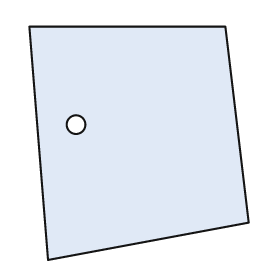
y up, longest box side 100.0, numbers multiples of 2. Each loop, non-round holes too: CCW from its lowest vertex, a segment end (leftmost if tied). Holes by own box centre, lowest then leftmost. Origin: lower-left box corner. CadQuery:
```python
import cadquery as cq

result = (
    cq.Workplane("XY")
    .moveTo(8.0, 0.0)
    .lineTo(94.0, 16.0)
    .lineTo(84.0, 100.0)
    .lineTo(0.0, 100.0)
    .close()
    .moveTo(20.0, 58.0)
    .circle(4.0)
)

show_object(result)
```